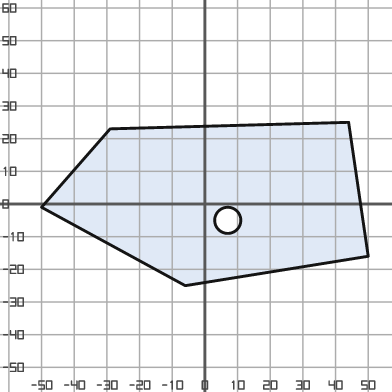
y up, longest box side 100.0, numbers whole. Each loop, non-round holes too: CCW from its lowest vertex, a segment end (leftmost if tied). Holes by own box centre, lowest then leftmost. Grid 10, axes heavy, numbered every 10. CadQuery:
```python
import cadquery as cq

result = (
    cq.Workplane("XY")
    .moveTo(-6.0, -25.0)
    .lineTo(50.0, -16.0)
    .lineTo(44.0, 25.0)
    .lineTo(-29.0, 23.0)
    .lineTo(-50.0, -1.0)
    .close()
    .moveTo(7.0, -5.0)
    .circle(4.0)
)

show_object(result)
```